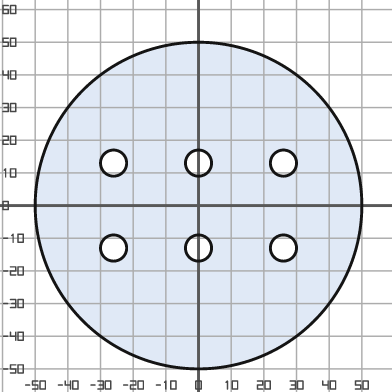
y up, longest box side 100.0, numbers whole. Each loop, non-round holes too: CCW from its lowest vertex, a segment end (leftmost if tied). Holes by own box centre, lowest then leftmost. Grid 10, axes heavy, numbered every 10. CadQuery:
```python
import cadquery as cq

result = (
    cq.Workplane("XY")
    .moveTo(0.0, 0.0)
    .circle(50.0)
    .moveTo(-26.0, -13.0)
    .circle(4.0)
    .moveTo(0.0, -13.0)
    .circle(4.0)
    .moveTo(26.0, -13.0)
    .circle(4.0)
    .moveTo(-26.0, 13.0)
    .circle(4.0)
    .moveTo(0.0, 13.0)
    .circle(4.0)
    .moveTo(26.0, 13.0)
    .circle(4.0)
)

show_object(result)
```